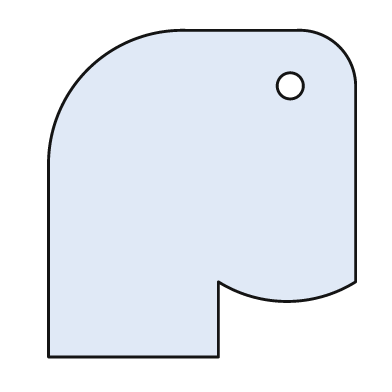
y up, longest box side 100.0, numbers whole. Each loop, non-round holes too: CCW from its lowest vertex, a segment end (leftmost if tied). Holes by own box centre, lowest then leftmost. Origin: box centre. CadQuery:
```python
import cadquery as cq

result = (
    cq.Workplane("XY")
    .moveTo(-47.0, -50.0)
    .lineTo(5.0, -50.0)
    .lineTo(5.0, -27.0)
    .threePointArc((26.0, -33.0), (47.0, -27.0))
    .lineTo(47.0, 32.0)
    .threePointArc((42.0, 45.0), (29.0, 50.0))
    .lineTo(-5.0, 50.0)
    .threePointArc((-35.0, 38.0), (-47.0, 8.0))
    .close()
    .moveTo(27.0, 33.0)
    .circle(4.0)
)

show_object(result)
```